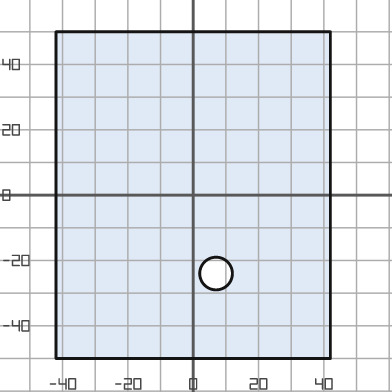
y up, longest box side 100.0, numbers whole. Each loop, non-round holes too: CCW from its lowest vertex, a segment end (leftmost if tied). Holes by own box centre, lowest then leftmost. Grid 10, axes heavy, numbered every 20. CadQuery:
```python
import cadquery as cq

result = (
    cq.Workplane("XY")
    .moveTo(-42.0, -50.0)
    .lineTo(42.0, -50.0)
    .lineTo(42.0, 50.0)
    .lineTo(-42.0, 50.0)
    .close()
    .moveTo(7.0, -24.0)
    .circle(5.0)
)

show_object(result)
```